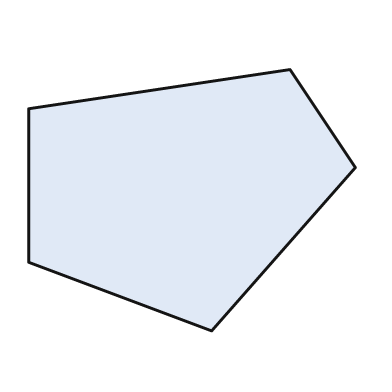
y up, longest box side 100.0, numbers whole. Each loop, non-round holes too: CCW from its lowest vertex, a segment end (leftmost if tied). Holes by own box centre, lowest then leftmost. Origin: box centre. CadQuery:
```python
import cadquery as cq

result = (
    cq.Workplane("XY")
    .moveTo(6.0, -40.0)
    .lineTo(50.0, 10.0)
    .lineTo(30.0, 40.0)
    .lineTo(-50.0, 28.0)
    .lineTo(-50.0, -19.0)
    .close()
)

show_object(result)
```